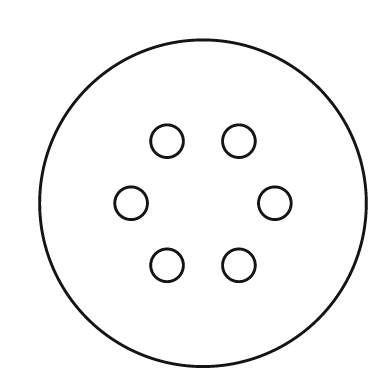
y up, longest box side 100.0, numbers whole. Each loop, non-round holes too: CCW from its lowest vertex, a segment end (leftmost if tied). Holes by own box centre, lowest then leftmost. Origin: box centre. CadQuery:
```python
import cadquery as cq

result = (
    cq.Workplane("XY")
    .moveTo(0.0, 0.0)
    .circle(50.0)
    .moveTo(-11.0, -19.0)
    .circle(5.0)
    .moveTo(11.0, -19.0)
    .circle(5.0)
    .moveTo(-22.0, 0.0)
    .circle(5.0)
    .moveTo(22.0, 0.0)
    .circle(5.0)
    .moveTo(-11.0, 19.0)
    .circle(5.0)
    .moveTo(11.0, 19.0)
    .circle(5.0)
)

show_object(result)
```